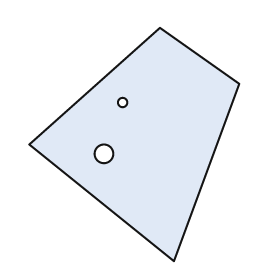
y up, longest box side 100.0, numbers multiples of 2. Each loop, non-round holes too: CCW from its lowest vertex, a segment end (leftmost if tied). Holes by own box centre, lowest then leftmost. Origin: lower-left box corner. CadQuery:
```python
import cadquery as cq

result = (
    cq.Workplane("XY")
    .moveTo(62.0, 0.0)
    .lineTo(90.0, 76.0)
    .lineTo(56.0, 100.0)
    .lineTo(0.0, 50.0)
    .close()
    .moveTo(32.0, 46.0)
    .circle(4.0)
    .moveTo(40.0, 68.0)
    .circle(2.0)
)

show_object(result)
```